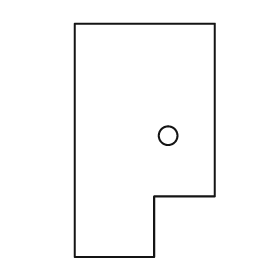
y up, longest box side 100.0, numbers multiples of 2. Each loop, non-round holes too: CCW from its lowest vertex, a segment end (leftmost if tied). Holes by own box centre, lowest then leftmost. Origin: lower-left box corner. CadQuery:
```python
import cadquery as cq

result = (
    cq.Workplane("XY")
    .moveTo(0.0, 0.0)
    .lineTo(34.0, 0.0)
    .lineTo(34.0, 26.0)
    .lineTo(60.0, 26.0)
    .lineTo(60.0, 100.0)
    .lineTo(0.0, 100.0)
    .close()
    .moveTo(40.0, 52.0)
    .circle(4.0)
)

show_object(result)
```